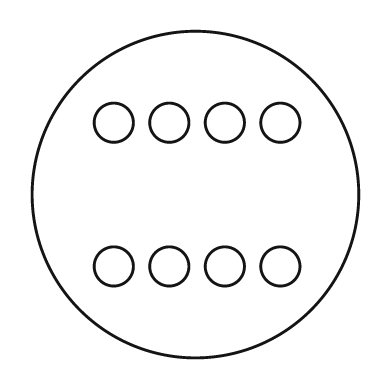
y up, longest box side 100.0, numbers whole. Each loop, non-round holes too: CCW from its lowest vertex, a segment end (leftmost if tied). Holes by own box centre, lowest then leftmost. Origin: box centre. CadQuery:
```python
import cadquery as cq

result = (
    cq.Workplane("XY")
    .moveTo(0.0, 0.0)
    .circle(50.0)
    .moveTo(-25.0, -22.0)
    .circle(6.0)
    .moveTo(-8.0, -22.0)
    .circle(6.0)
    .moveTo(9.0, -22.0)
    .circle(6.0)
    .moveTo(26.0, -22.0)
    .circle(6.0)
    .moveTo(-25.0, 22.0)
    .circle(6.0)
    .moveTo(-8.0, 22.0)
    .circle(6.0)
    .moveTo(9.0, 22.0)
    .circle(6.0)
    .moveTo(26.0, 22.0)
    .circle(6.0)
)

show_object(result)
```